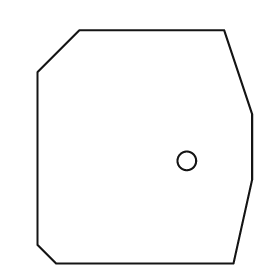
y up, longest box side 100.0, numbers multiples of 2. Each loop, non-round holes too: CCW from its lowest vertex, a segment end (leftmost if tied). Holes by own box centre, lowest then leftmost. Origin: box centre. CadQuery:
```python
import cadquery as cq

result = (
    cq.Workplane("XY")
    .moveTo(-38.0, -50.0)
    .lineTo(38.0, -50.0)
    .lineTo(46.0, -14.0)
    .lineTo(46.0, 14.0)
    .lineTo(34.0, 50.0)
    .lineTo(-28.0, 50.0)
    .lineTo(-46.0, 32.0)
    .lineTo(-46.0, -42.0)
    .close()
    .moveTo(18.0, -6.0)
    .circle(4.0)
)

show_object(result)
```